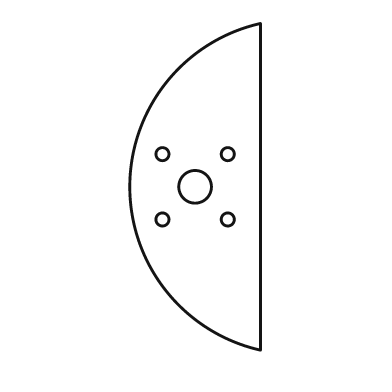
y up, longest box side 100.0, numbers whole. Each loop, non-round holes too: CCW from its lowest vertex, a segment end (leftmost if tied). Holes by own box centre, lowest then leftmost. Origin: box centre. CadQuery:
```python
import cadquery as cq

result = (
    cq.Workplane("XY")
    .moveTo(20.0, -50.0)
    .lineTo(20.0, 50.0)
    .threePointArc((-20.0, 0.0), (20.0, -50.0))
    .close()
    .moveTo(-10.0, -10.0)
    .circle(2.0)
    .moveTo(10.0, -10.0)
    .circle(2.0)
    .moveTo(0.0, 0.0)
    .circle(5.0)
    .moveTo(-10.0, 10.0)
    .circle(2.0)
    .moveTo(10.0, 10.0)
    .circle(2.0)
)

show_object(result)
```